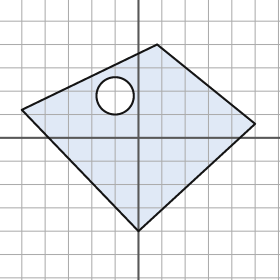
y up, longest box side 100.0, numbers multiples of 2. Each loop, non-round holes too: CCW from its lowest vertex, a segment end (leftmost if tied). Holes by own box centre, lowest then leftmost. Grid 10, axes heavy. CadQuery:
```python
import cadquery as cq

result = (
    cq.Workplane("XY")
    .moveTo(0.0, -40.0)
    .lineTo(50.0, 6.0)
    .lineTo(8.0, 40.0)
    .lineTo(-50.0, 12.0)
    .close()
    .moveTo(-10.0, 18.0)
    .circle(8.0)
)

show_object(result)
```